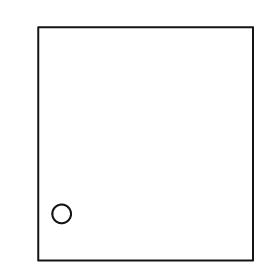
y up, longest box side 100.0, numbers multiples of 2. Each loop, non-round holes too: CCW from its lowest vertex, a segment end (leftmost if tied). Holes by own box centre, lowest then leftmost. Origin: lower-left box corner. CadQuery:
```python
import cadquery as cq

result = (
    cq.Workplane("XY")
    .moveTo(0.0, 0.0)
    .lineTo(92.0, 0.0)
    .lineTo(92.0, 100.0)
    .lineTo(0.0, 100.0)
    .close()
    .moveTo(10.0, 20.0)
    .circle(4.0)
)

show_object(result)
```